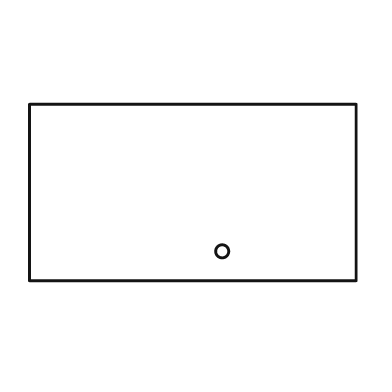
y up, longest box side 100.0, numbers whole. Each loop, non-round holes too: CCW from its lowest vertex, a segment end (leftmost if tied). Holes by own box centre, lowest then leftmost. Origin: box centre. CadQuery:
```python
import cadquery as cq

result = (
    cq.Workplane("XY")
    .moveTo(-50.0, -27.0)
    .lineTo(50.0, -27.0)
    .lineTo(50.0, 27.0)
    .lineTo(-50.0, 27.0)
    .close()
    .moveTo(9.0, -18.0)
    .circle(2.0)
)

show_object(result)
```